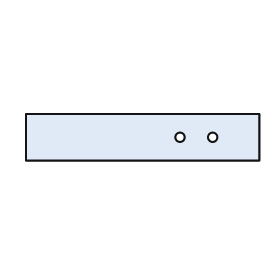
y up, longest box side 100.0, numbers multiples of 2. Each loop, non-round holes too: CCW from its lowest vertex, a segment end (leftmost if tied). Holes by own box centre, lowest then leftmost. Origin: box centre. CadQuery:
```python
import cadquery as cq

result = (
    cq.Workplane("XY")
    .moveTo(-50.0, -10.0)
    .lineTo(50.0, -10.0)
    .lineTo(50.0, 10.0)
    .lineTo(-50.0, 10.0)
    .close()
    .moveTo(16.0, 0.0)
    .circle(2.0)
    .moveTo(30.0, 0.0)
    .circle(2.0)
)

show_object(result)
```